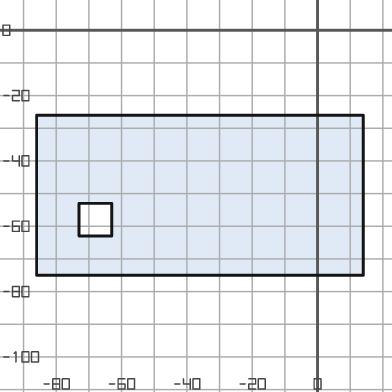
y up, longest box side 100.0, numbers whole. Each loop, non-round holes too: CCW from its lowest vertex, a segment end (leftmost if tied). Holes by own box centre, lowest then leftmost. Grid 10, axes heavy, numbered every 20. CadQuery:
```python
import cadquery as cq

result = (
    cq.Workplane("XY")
    .moveTo(-86.0, -75.0)
    .lineTo(14.0, -75.0)
    .lineTo(14.0, -26.0)
    .lineTo(-86.0, -26.0)
    .close()
    .moveTo(-73.0, -63.0)
    .lineTo(-63.0, -63.0)
    .lineTo(-63.0, -53.0)
    .lineTo(-73.0, -53.0)
    .close()
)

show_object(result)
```